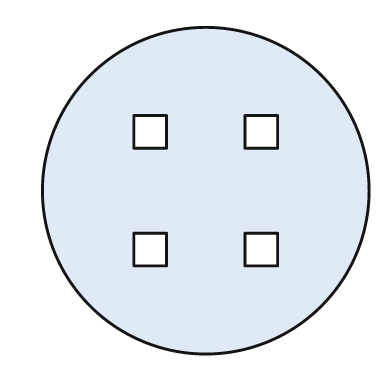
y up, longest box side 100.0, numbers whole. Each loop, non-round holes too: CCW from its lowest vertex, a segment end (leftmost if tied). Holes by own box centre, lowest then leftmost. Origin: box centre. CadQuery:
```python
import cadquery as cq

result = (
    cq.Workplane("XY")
    .moveTo(0.0, 0.0)
    .circle(50.0)
    .moveTo(-22.0, -23.0)
    .lineTo(-12.0, -23.0)
    .lineTo(-12.0, -13.0)
    .lineTo(-22.0, -13.0)
    .close()
    .moveTo(12.0, -23.0)
    .lineTo(22.0, -23.0)
    .lineTo(22.0, -13.0)
    .lineTo(12.0, -13.0)
    .close()
    .moveTo(-22.0, 13.0)
    .lineTo(-12.0, 13.0)
    .lineTo(-12.0, 23.0)
    .lineTo(-22.0, 23.0)
    .close()
    .moveTo(12.0, 13.0)
    .lineTo(22.0, 13.0)
    .lineTo(22.0, 23.0)
    .lineTo(12.0, 23.0)
    .close()
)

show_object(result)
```